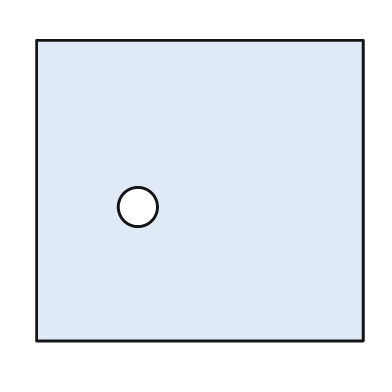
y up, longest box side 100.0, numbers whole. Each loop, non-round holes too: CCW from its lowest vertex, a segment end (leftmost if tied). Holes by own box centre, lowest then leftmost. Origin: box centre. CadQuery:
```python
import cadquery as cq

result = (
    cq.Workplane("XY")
    .moveTo(-50.0, -46.0)
    .lineTo(50.0, -46.0)
    .lineTo(50.0, 46.0)
    .lineTo(-50.0, 46.0)
    .close()
    .moveTo(-19.0, -5.0)
    .circle(6.0)
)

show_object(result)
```